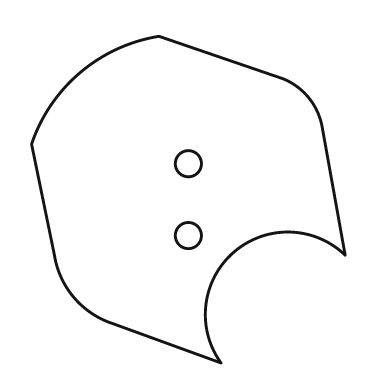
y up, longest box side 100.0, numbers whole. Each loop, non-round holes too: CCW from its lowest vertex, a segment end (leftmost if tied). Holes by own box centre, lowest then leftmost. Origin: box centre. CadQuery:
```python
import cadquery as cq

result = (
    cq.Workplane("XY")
    .moveTo(10.0, -50.0)
    .threePointArc((14.0, -16.0), (48.0, -17.0))
    .lineTo(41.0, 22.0)
    .threePointArc((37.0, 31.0), (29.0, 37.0))
    .lineTo(-9.0, 50.0)
    .threePointArc((-33.0, 39.0), (-48.0, 17.0))
    .lineTo(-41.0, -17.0)
    .threePointArc((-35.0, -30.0), (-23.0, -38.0))
    .close()
    .moveTo(0.0, -11.0)
    .circle(4.0)
    .moveTo(0.0, 11.0)
    .circle(4.0)
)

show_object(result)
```